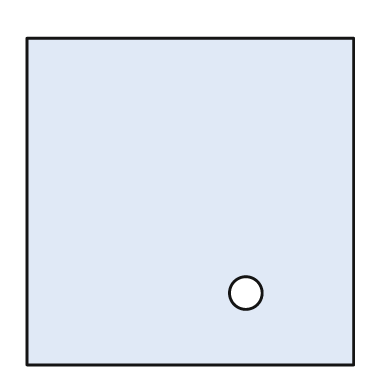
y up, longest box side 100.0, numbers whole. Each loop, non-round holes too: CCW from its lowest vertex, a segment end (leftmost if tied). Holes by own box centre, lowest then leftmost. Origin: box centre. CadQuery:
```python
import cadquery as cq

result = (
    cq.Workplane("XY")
    .moveTo(-50.0, -50.0)
    .lineTo(50.0, -50.0)
    .lineTo(50.0, 50.0)
    .lineTo(-50.0, 50.0)
    .close()
    .moveTo(17.0, -28.0)
    .circle(5.0)
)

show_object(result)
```